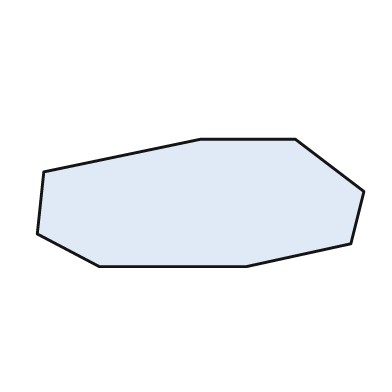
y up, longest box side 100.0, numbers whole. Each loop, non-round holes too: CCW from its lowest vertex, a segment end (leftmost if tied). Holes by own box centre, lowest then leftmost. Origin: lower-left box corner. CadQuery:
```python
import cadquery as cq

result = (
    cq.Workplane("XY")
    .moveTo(19.0, 0.0)
    .lineTo(64.0, 0.0)
    .lineTo(96.0, 7.0)
    .lineTo(100.0, 23.0)
    .lineTo(79.0, 39.0)
    .lineTo(50.0, 39.0)
    .lineTo(2.0, 29.0)
    .lineTo(0.0, 10.0)
    .close()
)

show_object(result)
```